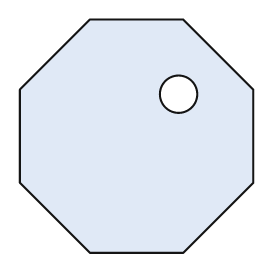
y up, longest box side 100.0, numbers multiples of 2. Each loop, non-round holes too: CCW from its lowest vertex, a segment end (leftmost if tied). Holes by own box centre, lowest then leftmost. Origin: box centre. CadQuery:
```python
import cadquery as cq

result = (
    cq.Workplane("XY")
    .moveTo(-20.0, -50.0)
    .lineTo(20.0, -50.0)
    .lineTo(50.0, -20.0)
    .lineTo(50.0, 20.0)
    .lineTo(20.0, 50.0)
    .lineTo(-20.0, 50.0)
    .lineTo(-50.0, 20.0)
    .lineTo(-50.0, -20.0)
    .close()
    .moveTo(18.0, 18.0)
    .circle(8.0)
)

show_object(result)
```